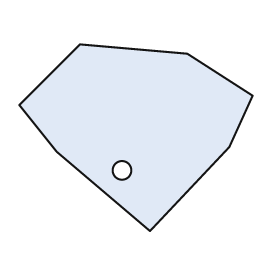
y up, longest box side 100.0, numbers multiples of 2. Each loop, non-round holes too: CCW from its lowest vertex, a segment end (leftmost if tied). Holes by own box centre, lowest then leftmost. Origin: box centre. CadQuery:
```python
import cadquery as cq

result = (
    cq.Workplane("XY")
    .moveTo(6.0, -40.0)
    .lineTo(40.0, -4.0)
    .lineTo(50.0, 18.0)
    .lineTo(22.0, 36.0)
    .lineTo(-24.0, 40.0)
    .lineTo(-50.0, 14.0)
    .lineTo(-34.0, -6.0)
    .close()
    .moveTo(-6.0, -14.0)
    .circle(4.0)
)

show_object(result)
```